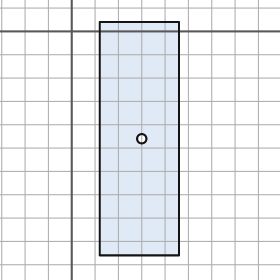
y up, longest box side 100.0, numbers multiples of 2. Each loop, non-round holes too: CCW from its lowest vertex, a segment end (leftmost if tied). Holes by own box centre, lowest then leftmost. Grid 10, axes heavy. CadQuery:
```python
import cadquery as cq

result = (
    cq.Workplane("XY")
    .moveTo(12.0, -96.0)
    .lineTo(46.0, -96.0)
    .lineTo(46.0, 4.0)
    .lineTo(12.0, 4.0)
    .close()
    .moveTo(30.0, -46.0)
    .circle(2.0)
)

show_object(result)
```